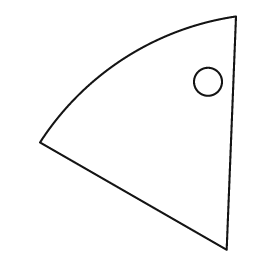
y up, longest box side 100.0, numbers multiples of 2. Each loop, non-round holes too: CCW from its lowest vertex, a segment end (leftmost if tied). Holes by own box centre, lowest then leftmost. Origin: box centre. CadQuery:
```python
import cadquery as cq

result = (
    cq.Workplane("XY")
    .moveTo(38.0, -50.0)
    .lineTo(42.0, 50.0)
    .threePointArc((-6.0, 32.0), (-42.0, -4.0))
    .close()
    .moveTo(30.0, 22.0)
    .circle(6.0)
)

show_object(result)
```